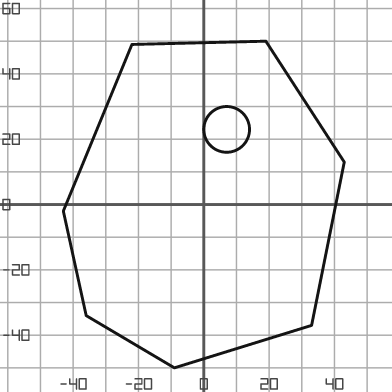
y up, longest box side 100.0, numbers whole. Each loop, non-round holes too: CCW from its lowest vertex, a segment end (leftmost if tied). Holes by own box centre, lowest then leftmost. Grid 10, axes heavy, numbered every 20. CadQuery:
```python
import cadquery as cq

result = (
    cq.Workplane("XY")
    .moveTo(-9.0, -50.0)
    .lineTo(33.0, -37.0)
    .lineTo(43.0, 13.0)
    .lineTo(19.0, 50.0)
    .lineTo(-22.0, 49.0)
    .lineTo(-43.0, -2.0)
    .lineTo(-36.0, -34.0)
    .close()
    .moveTo(7.0, 23.0)
    .circle(7.0)
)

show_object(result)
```